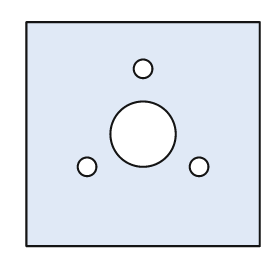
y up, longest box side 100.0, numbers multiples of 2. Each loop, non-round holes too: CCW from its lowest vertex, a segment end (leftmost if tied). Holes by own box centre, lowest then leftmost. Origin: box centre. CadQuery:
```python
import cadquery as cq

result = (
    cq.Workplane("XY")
    .moveTo(-50.0, -48.0)
    .lineTo(50.0, -48.0)
    .lineTo(50.0, 48.0)
    .lineTo(-50.0, 48.0)
    .close()
    .moveTo(-24.0, -14.0)
    .circle(4.0)
    .moveTo(24.0, -14.0)
    .circle(4.0)
    .moveTo(0.0, 0.0)
    .circle(14.0)
    .moveTo(0.0, 28.0)
    .circle(4.0)
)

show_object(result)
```